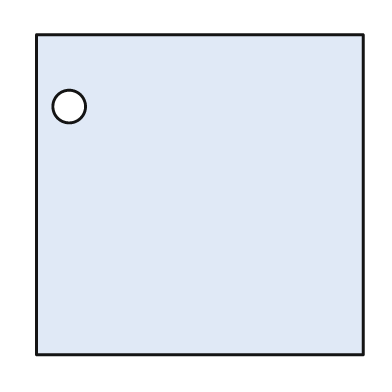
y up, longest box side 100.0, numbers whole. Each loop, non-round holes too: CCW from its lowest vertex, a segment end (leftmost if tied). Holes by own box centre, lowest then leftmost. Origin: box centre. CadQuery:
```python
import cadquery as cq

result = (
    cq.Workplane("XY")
    .moveTo(-50.0, -49.0)
    .lineTo(50.0, -49.0)
    .lineTo(50.0, 49.0)
    .lineTo(-50.0, 49.0)
    .close()
    .moveTo(-40.0, 27.0)
    .circle(5.0)
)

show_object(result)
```